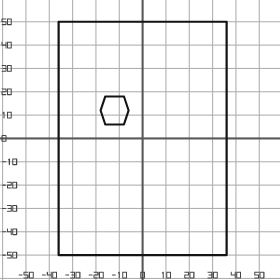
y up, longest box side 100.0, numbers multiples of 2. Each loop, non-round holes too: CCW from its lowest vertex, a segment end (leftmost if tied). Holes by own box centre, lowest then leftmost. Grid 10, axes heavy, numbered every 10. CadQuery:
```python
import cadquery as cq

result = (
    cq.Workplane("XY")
    .moveTo(-36.0, -50.0)
    .lineTo(36.0, -50.0)
    .lineTo(36.0, 50.0)
    .lineTo(-36.0, 50.0)
    .close()
    .moveTo(-16.0, 6.0)
    .lineTo(-8.0, 6.0)
    .lineTo(-6.0, 12.0)
    .lineTo(-8.0, 18.0)
    .lineTo(-16.0, 18.0)
    .lineTo(-18.0, 12.0)
    .close()
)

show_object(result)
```